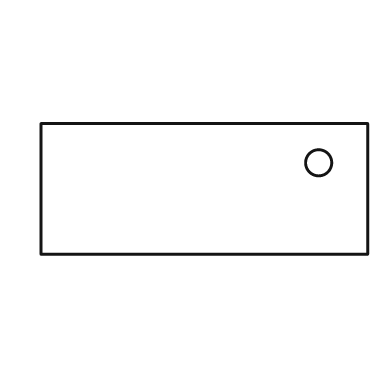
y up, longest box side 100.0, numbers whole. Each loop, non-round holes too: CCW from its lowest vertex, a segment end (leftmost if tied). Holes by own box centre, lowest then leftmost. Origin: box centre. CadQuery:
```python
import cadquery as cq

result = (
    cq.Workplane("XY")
    .moveTo(-50.0, -20.0)
    .lineTo(50.0, -20.0)
    .lineTo(50.0, 20.0)
    .lineTo(-50.0, 20.0)
    .close()
    .moveTo(35.0, 8.0)
    .circle(4.0)
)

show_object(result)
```